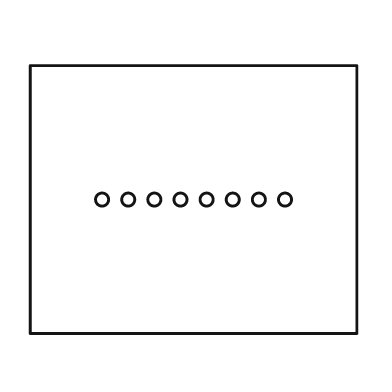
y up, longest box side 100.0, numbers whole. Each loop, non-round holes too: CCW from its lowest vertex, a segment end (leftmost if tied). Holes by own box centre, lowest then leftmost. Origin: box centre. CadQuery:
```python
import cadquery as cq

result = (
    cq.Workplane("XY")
    .moveTo(-50.0, -41.0)
    .lineTo(50.0, -41.0)
    .lineTo(50.0, 41.0)
    .lineTo(-50.0, 41.0)
    .close()
    .moveTo(-28.0, 0.0)
    .circle(2.0)
    .moveTo(-20.0, 0.0)
    .circle(2.0)
    .moveTo(-12.0, 0.0)
    .circle(2.0)
    .moveTo(-4.0, 0.0)
    .circle(2.0)
    .moveTo(4.0, 0.0)
    .circle(2.0)
    .moveTo(12.0, 0.0)
    .circle(2.0)
    .moveTo(20.0, 0.0)
    .circle(2.0)
    .moveTo(28.0, 0.0)
    .circle(2.0)
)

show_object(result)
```